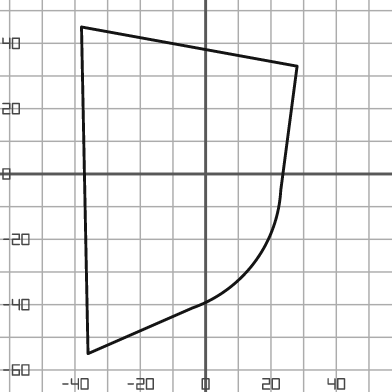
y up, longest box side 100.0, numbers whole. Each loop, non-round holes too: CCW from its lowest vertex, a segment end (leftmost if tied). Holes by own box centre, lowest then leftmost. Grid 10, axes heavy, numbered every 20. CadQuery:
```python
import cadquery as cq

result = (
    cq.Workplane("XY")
    .moveTo(-36.0, -55.0)
    .lineTo(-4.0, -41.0)
    .threePointArc((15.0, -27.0), (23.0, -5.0))
    .lineTo(28.0, 33.0)
    .lineTo(-38.0, 45.0)
    .close()
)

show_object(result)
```